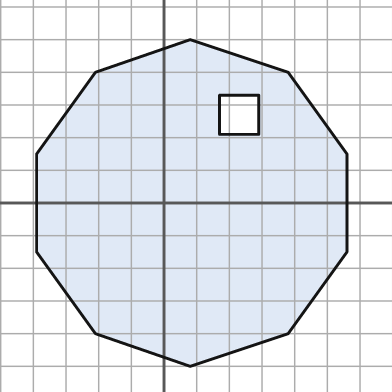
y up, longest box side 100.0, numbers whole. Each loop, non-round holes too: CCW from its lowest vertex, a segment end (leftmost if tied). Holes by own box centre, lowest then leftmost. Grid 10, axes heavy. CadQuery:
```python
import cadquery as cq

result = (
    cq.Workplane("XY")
    .moveTo(8.0, -50.0)
    .lineTo(38.0, -40.0)
    .lineTo(56.0, -15.0)
    .lineTo(56.0, 15.0)
    .lineTo(38.0, 40.0)
    .lineTo(8.0, 50.0)
    .lineTo(-21.0, 40.0)
    .lineTo(-39.0, 15.0)
    .lineTo(-39.0, -15.0)
    .lineTo(-21.0, -40.0)
    .close()
    .moveTo(17.0, 21.0)
    .lineTo(29.0, 21.0)
    .lineTo(29.0, 33.0)
    .lineTo(17.0, 33.0)
    .close()
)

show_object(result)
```